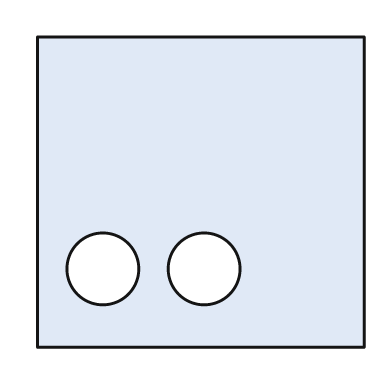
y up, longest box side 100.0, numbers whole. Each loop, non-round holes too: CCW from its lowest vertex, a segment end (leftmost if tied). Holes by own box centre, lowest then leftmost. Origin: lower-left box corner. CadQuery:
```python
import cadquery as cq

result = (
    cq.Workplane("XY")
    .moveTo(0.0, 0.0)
    .lineTo(100.0, 0.0)
    .lineTo(100.0, 95.0)
    .lineTo(0.0, 95.0)
    .close()
    .moveTo(20.0, 24.0)
    .circle(11.0)
    .moveTo(51.0, 24.0)
    .circle(11.0)
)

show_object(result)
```